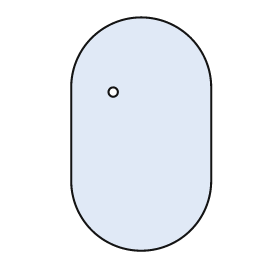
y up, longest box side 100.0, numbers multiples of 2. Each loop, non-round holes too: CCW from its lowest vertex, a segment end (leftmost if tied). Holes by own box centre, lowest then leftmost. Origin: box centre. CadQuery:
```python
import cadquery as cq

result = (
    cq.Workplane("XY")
    .moveTo(-30.0, -20.0)
    .threePointArc((0.0, -50.0), (30.0, -20.0))
    .lineTo(30.0, 20.0)
    .threePointArc((0.0, 50.0), (-30.0, 20.0))
    .close()
    .moveTo(-12.0, 18.0)
    .circle(2.0)
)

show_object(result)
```